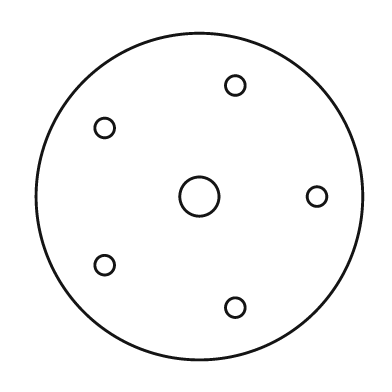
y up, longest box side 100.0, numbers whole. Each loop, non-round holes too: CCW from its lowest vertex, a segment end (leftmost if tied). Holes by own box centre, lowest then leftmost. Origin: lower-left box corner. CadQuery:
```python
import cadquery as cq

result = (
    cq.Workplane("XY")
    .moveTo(50.0, 50.0)
    .circle(50.0)
    .moveTo(61.0, 16.0)
    .circle(3.0)
    .moveTo(21.0, 29.0)
    .circle(3.0)
    .moveTo(50.0, 50.0)
    .circle(6.0)
    .moveTo(86.0, 50.0)
    .circle(3.0)
    .moveTo(21.0, 71.0)
    .circle(3.0)
    .moveTo(61.0, 84.0)
    .circle(3.0)
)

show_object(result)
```